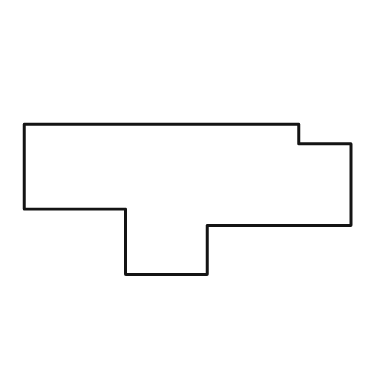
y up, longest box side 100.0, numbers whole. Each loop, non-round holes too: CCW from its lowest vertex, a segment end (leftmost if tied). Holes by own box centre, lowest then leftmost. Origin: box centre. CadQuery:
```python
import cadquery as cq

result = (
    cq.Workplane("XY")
    .moveTo(-19.0, -23.0)
    .lineTo(6.0, -23.0)
    .lineTo(6.0, -8.0)
    .lineTo(50.0, -8.0)
    .lineTo(50.0, 17.0)
    .lineTo(34.0, 17.0)
    .lineTo(34.0, 23.0)
    .lineTo(-50.0, 23.0)
    .lineTo(-50.0, -3.0)
    .lineTo(-19.0, -3.0)
    .close()
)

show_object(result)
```